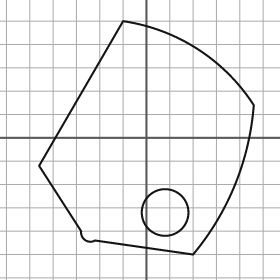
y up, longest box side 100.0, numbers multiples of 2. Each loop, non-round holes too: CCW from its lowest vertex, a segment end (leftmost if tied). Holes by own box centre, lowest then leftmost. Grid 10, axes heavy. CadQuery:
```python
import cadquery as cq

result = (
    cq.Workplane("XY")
    .moveTo(20.0, -50.0)
    .threePointArc((38.0, -20.0), (46.0, 14.0))
    .threePointArc((22.0, 38.0), (-10.0, 50.0))
    .lineTo(-46.0, -12.0)
    .lineTo(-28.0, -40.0)
    .threePointArc((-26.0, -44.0), (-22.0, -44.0))
    .close()
    .moveTo(8.0, -32.0)
    .circle(10.0)
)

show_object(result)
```